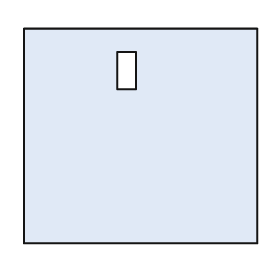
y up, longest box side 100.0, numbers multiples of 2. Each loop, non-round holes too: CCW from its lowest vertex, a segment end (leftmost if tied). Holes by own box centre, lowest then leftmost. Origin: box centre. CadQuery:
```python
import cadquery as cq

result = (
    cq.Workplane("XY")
    .moveTo(-50.0, -46.0)
    .lineTo(50.0, -46.0)
    .lineTo(50.0, 46.0)
    .lineTo(-50.0, 46.0)
    .close()
    .moveTo(-10.0, 20.0)
    .lineTo(-2.0, 20.0)
    .lineTo(-2.0, 36.0)
    .lineTo(-10.0, 36.0)
    .close()
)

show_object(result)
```